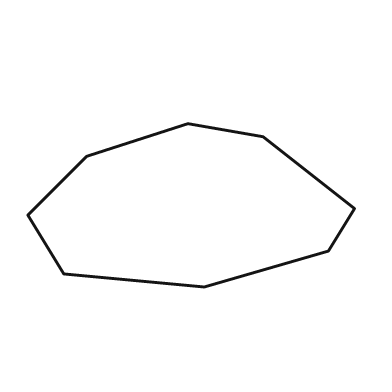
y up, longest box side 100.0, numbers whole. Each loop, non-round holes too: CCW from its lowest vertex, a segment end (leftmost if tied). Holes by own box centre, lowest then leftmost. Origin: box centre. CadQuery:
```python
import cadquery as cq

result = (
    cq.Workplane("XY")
    .moveTo(4.0, -25.0)
    .lineTo(42.0, -14.0)
    .lineTo(50.0, -1.0)
    .lineTo(22.0, 21.0)
    .lineTo(-1.0, 25.0)
    .lineTo(-32.0, 15.0)
    .lineTo(-50.0, -3.0)
    .lineTo(-39.0, -21.0)
    .close()
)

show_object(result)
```